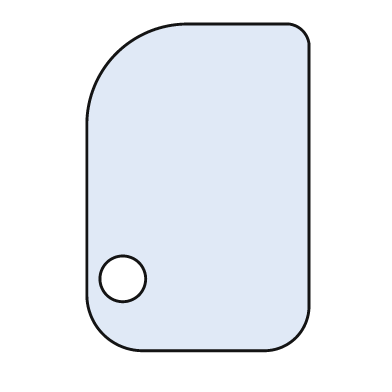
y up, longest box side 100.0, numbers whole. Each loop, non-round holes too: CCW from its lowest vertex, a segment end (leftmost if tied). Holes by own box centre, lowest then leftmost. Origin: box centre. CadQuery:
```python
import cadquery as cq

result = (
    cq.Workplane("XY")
    .moveTo(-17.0, -50.0)
    .lineTo(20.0, -50.0)
    .threePointArc((30.0, -46.0), (34.0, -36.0))
    .lineTo(34.0, 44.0)
    .threePointArc((32.0, 48.0), (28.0, 50.0))
    .lineTo(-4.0, 50.0)
    .threePointArc((-25.0, 41.0), (-34.0, 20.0))
    .lineTo(-34.0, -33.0)
    .threePointArc((-29.0, -45.0), (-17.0, -50.0))
    .close()
    .moveTo(-23.0, -28.0)
    .circle(7.0)
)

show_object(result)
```